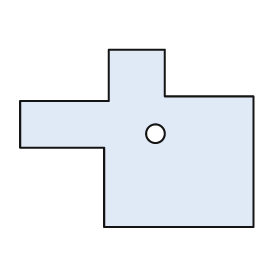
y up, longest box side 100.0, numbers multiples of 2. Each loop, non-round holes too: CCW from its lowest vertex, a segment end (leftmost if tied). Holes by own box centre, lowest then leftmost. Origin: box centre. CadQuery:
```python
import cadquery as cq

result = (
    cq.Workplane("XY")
    .moveTo(-14.0, -38.0)
    .lineTo(50.0, -38.0)
    .lineTo(50.0, 18.0)
    .lineTo(12.0, 18.0)
    .lineTo(12.0, 38.0)
    .lineTo(-12.0, 38.0)
    .lineTo(-12.0, 16.0)
    .lineTo(-50.0, 16.0)
    .lineTo(-50.0, -4.0)
    .lineTo(-14.0, -4.0)
    .close()
    .moveTo(8.0, 2.0)
    .circle(4.0)
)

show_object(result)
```